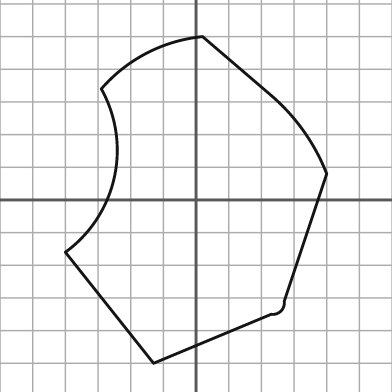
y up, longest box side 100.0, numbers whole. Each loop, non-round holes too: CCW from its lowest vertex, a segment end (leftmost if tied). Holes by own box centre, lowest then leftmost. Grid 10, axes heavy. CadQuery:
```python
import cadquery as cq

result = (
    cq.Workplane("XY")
    .moveTo(-13.0, -50.0)
    .lineTo(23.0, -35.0)
    .threePointArc((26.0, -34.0), (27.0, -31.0))
    .lineTo(40.0, 8.0)
    .threePointArc((33.0, 21.0), (23.0, 32.0))
    .lineTo(2.0, 50.0)
    .threePointArc((-15.0, 45.0), (-29.0, 34.0))
    .threePointArc((-25.0, 7.0), (-40.0, -16.0))
    .close()
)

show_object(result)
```